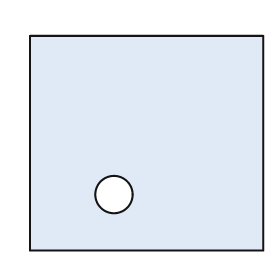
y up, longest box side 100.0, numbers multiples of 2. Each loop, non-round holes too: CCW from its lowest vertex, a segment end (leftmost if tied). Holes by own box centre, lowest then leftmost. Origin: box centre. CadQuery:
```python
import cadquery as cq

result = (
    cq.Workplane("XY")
    .moveTo(-50.0, -46.0)
    .lineTo(50.0, -46.0)
    .lineTo(50.0, 46.0)
    .lineTo(-50.0, 46.0)
    .close()
    .moveTo(-14.0, -22.0)
    .circle(8.0)
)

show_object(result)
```